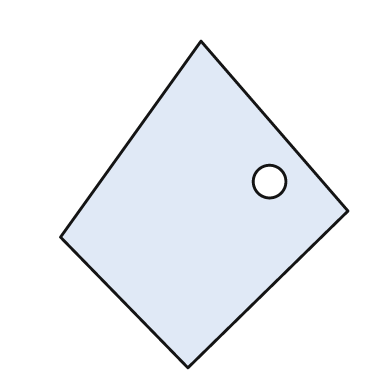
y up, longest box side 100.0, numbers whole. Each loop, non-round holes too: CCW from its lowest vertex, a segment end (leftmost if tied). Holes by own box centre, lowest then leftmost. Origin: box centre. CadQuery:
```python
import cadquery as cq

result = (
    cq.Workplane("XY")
    .moveTo(-5.0, -50.0)
    .lineTo(44.0, -2.0)
    .lineTo(-1.0, 50.0)
    .lineTo(-44.0, -10.0)
    .close()
    .moveTo(20.0, 7.0)
    .circle(5.0)
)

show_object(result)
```